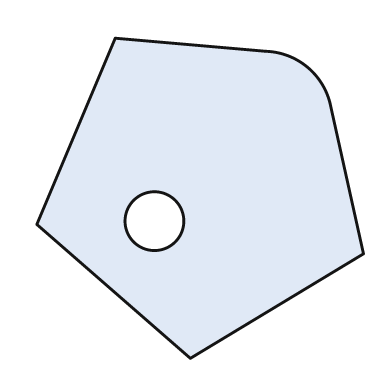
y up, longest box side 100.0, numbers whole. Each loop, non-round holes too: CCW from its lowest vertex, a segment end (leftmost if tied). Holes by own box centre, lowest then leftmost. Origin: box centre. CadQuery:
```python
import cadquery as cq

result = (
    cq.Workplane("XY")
    .moveTo(-3.0, -49.0)
    .lineTo(50.0, -17.0)
    .lineTo(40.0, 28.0)
    .threePointArc((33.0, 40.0), (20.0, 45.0))
    .lineTo(-26.0, 49.0)
    .lineTo(-50.0, -8.0)
    .close()
    .moveTo(-14.0, -7.0)
    .circle(9.0)
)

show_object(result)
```